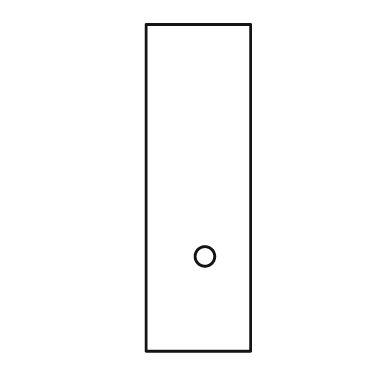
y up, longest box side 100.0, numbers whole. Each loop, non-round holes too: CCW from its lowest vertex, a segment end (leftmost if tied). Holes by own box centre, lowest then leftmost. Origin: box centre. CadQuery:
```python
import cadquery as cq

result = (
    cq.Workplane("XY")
    .moveTo(-16.0, -50.0)
    .lineTo(16.0, -50.0)
    .lineTo(16.0, 50.0)
    .lineTo(-16.0, 50.0)
    .close()
    .moveTo(2.0, -21.0)
    .circle(3.0)
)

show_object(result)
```